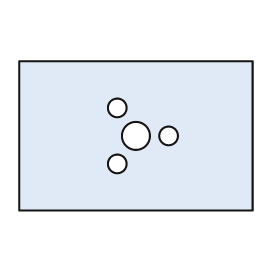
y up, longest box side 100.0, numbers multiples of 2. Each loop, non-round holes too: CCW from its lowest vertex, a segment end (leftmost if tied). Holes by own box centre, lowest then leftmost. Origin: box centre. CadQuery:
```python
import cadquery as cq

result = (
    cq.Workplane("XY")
    .moveTo(-50.0, -32.0)
    .lineTo(50.0, -32.0)
    .lineTo(50.0, 32.0)
    .lineTo(-50.0, 32.0)
    .close()
    .moveTo(-8.0, -12.0)
    .circle(4.0)
    .moveTo(0.0, 0.0)
    .circle(6.0)
    .moveTo(14.0, 0.0)
    .circle(4.0)
    .moveTo(-8.0, 12.0)
    .circle(4.0)
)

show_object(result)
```